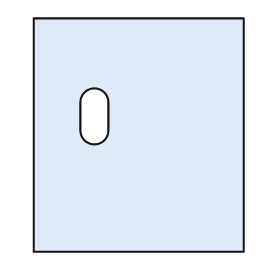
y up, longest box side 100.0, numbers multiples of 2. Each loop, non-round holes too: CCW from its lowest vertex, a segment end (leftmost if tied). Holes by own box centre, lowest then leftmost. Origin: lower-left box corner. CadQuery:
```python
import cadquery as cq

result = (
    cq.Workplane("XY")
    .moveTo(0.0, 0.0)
    .lineTo(90.0, 0.0)
    .lineTo(90.0, 100.0)
    .lineTo(0.0, 100.0)
    .close()
    .moveTo(20.0, 52.0)
    .threePointArc((26.0, 46.0), (32.0, 52.0))
    .lineTo(32.0, 64.0)
    .threePointArc((26.0, 70.0), (20.0, 64.0))
    .close()
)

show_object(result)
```